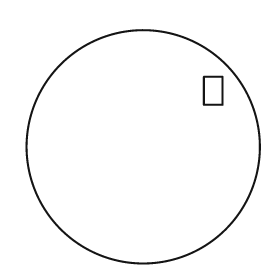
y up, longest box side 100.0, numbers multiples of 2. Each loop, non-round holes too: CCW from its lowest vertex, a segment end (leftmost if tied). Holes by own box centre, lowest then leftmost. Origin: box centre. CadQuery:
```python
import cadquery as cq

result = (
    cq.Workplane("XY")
    .moveTo(0.0, 0.0)
    .circle(50.0)
    .moveTo(26.0, 18.0)
    .lineTo(34.0, 18.0)
    .lineTo(34.0, 30.0)
    .lineTo(26.0, 30.0)
    .close()
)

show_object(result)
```